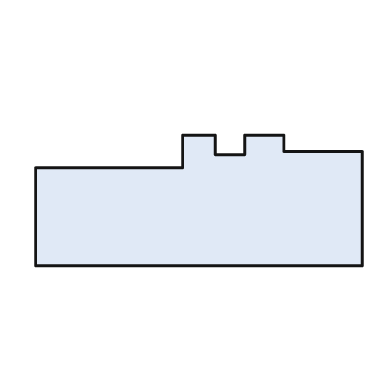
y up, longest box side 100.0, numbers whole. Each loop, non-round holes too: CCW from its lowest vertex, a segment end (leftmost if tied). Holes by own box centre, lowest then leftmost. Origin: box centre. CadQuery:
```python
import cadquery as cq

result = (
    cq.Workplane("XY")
    .moveTo(-50.0, -20.0)
    .lineTo(50.0, -20.0)
    .lineTo(50.0, 15.0)
    .lineTo(26.0, 15.0)
    .lineTo(26.0, 20.0)
    .lineTo(14.0, 20.0)
    .lineTo(14.0, 14.0)
    .lineTo(5.0, 14.0)
    .lineTo(5.0, 20.0)
    .lineTo(-5.0, 20.0)
    .lineTo(-5.0, 10.0)
    .lineTo(-50.0, 10.0)
    .close()
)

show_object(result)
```